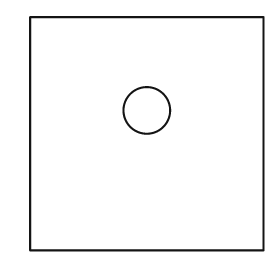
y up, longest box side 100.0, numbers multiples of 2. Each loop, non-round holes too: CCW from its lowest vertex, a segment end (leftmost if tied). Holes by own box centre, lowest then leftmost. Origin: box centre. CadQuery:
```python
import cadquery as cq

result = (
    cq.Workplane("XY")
    .moveTo(-50.0, -50.0)
    .lineTo(50.0, -50.0)
    .lineTo(50.0, 50.0)
    .lineTo(-50.0, 50.0)
    .close()
    .moveTo(0.0, 10.0)
    .circle(10.0)
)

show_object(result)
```